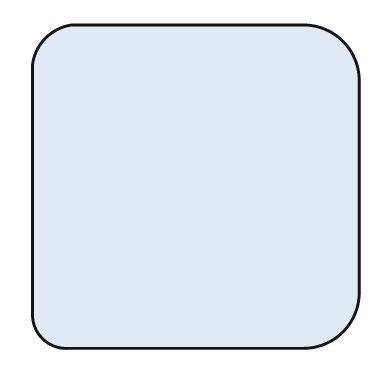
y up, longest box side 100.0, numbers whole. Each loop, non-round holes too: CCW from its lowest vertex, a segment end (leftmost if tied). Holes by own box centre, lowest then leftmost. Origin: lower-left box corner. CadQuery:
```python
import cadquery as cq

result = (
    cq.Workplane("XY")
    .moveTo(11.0, 0.0)
    .lineTo(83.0, 0.0)
    .threePointArc((95.0, 5.0), (100.0, 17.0))
    .lineTo(100.0, 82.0)
    .threePointArc((95.0, 94.0), (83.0, 99.0))
    .lineTo(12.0, 99.0)
    .threePointArc((4.0, 95.0), (0.0, 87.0))
    .lineTo(0.0, 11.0)
    .threePointArc((3.0, 3.0), (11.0, 0.0))
    .close()
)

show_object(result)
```